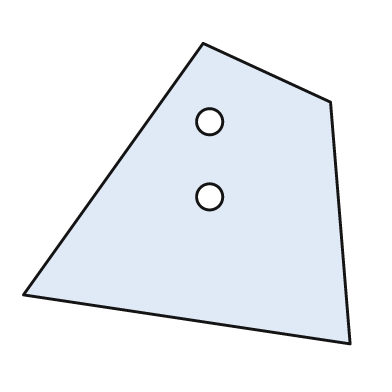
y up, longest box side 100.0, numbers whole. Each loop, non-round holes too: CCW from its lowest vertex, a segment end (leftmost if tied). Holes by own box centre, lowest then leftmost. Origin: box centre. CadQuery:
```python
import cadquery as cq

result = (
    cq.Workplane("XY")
    .moveTo(50.0, -46.0)
    .lineTo(44.0, 28.0)
    .lineTo(5.0, 46.0)
    .lineTo(-50.0, -31.0)
    .close()
    .moveTo(7.0, -1.0)
    .circle(4.0)
    .moveTo(7.0, 22.0)
    .circle(4.0)
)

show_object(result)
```